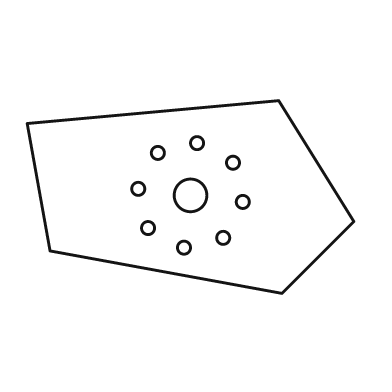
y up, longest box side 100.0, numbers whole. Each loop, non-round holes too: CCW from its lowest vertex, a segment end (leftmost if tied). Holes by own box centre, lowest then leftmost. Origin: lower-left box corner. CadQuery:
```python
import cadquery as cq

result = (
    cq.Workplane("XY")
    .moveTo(78.0, 0.0)
    .lineTo(100.0, 22.0)
    .lineTo(77.0, 59.0)
    .lineTo(0.0, 52.0)
    .lineTo(7.0, 13.0)
    .close()
    .moveTo(48.0, 14.0)
    .circle(2.0)
    .moveTo(60.0, 17.0)
    .circle(2.0)
    .moveTo(37.0, 20.0)
    .circle(2.0)
    .moveTo(66.0, 28.0)
    .circle(2.0)
    .moveTo(50.0, 30.0)
    .circle(5.0)
    .moveTo(34.0, 32.0)
    .circle(2.0)
    .moveTo(63.0, 40.0)
    .circle(2.0)
    .moveTo(40.0, 43.0)
    .circle(2.0)
    .moveTo(52.0, 46.0)
    .circle(2.0)
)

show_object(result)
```